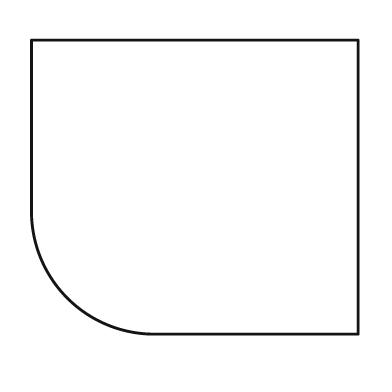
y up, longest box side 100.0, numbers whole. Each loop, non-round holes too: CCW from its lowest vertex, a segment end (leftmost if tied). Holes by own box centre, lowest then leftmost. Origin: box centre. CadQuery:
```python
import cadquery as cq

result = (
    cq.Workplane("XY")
    .moveTo(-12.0, -45.0)
    .lineTo(50.0, -45.0)
    .lineTo(50.0, 45.0)
    .lineTo(-50.0, 45.0)
    .lineTo(-50.0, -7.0)
    .threePointArc((-39.0, -34.0), (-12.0, -45.0))
    .close()
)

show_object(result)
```